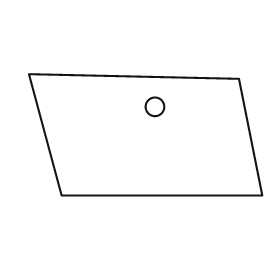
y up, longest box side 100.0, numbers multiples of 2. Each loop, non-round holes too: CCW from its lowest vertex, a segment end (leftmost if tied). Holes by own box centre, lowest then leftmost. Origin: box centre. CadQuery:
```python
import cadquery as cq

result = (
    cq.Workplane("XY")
    .moveTo(-36.0, -26.0)
    .lineTo(50.0, -26.0)
    .lineTo(40.0, 24.0)
    .lineTo(-50.0, 26.0)
    .close()
    .moveTo(4.0, 12.0)
    .circle(4.0)
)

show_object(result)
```